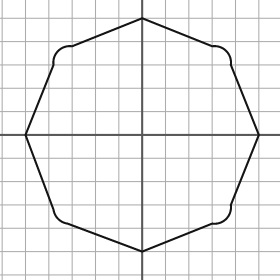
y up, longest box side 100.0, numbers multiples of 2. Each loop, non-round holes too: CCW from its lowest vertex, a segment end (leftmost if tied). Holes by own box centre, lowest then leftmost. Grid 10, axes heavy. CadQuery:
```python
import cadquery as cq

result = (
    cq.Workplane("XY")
    .moveTo(0.0, -50.0)
    .lineTo(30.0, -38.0)
    .threePointArc((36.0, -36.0), (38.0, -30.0))
    .lineTo(50.0, 0.0)
    .lineTo(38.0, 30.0)
    .threePointArc((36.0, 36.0), (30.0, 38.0))
    .lineTo(0.0, 50.0)
    .lineTo(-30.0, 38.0)
    .threePointArc((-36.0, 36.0), (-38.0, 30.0))
    .lineTo(-50.0, 0.0)
    .lineTo(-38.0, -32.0)
    .threePointArc((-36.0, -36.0), (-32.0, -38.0))
    .close()
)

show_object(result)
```